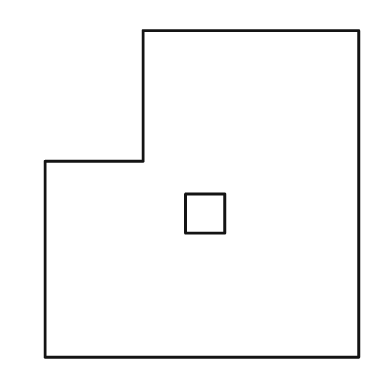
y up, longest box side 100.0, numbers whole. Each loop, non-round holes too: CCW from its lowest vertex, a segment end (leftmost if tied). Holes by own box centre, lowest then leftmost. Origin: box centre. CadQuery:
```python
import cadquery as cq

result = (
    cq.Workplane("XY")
    .moveTo(-48.0, -50.0)
    .lineTo(48.0, -50.0)
    .lineTo(48.0, 50.0)
    .lineTo(-18.0, 50.0)
    .lineTo(-18.0, 10.0)
    .lineTo(-48.0, 10.0)
    .close()
    .moveTo(-5.0, -12.0)
    .lineTo(7.0, -12.0)
    .lineTo(7.0, 0.0)
    .lineTo(-5.0, 0.0)
    .close()
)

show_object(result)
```